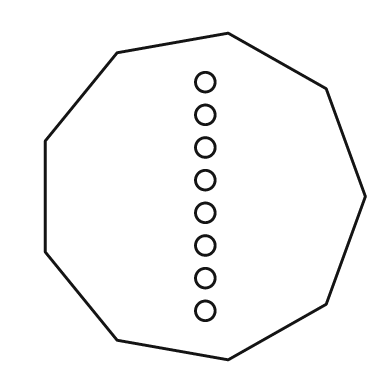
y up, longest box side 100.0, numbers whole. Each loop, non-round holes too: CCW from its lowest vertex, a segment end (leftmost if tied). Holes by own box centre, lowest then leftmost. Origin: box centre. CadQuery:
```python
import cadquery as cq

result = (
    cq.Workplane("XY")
    .moveTo(7.0, -50.0)
    .lineTo(37.0, -33.0)
    .lineTo(49.0, 0.0)
    .lineTo(37.0, 33.0)
    .lineTo(7.0, 50.0)
    .lineTo(-27.0, 44.0)
    .lineTo(-49.0, 17.0)
    .lineTo(-49.0, -17.0)
    .lineTo(-27.0, -44.0)
    .close()
    .moveTo(0.0, -35.0)
    .circle(3.0)
    .moveTo(0.0, -25.0)
    .circle(3.0)
    .moveTo(0.0, -15.0)
    .circle(3.0)
    .moveTo(0.0, -5.0)
    .circle(3.0)
    .moveTo(0.0, 5.0)
    .circle(3.0)
    .moveTo(0.0, 15.0)
    .circle(3.0)
    .moveTo(0.0, 25.0)
    .circle(3.0)
    .moveTo(0.0, 35.0)
    .circle(3.0)
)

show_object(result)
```